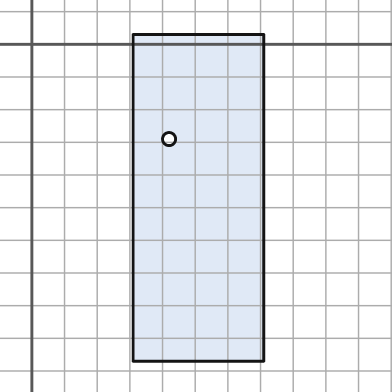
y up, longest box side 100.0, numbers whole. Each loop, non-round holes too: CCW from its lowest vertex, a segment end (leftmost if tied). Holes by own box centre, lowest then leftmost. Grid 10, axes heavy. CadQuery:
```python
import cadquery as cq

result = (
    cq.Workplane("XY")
    .moveTo(31.0, -97.0)
    .lineTo(71.0, -97.0)
    .lineTo(71.0, 3.0)
    .lineTo(31.0, 3.0)
    .close()
    .moveTo(42.0, -29.0)
    .circle(2.0)
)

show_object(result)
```